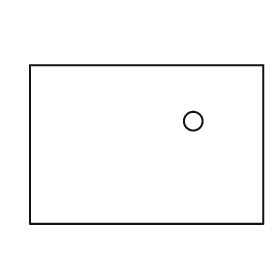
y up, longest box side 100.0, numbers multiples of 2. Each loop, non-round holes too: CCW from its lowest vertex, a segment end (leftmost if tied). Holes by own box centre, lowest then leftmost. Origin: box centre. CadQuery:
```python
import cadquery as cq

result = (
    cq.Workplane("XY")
    .moveTo(-50.0, -34.0)
    .lineTo(50.0, -34.0)
    .lineTo(50.0, 34.0)
    .lineTo(-50.0, 34.0)
    .close()
    .moveTo(20.0, 10.0)
    .circle(4.0)
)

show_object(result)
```